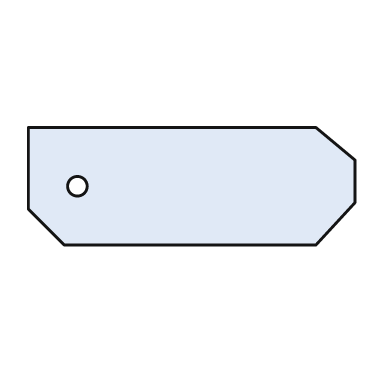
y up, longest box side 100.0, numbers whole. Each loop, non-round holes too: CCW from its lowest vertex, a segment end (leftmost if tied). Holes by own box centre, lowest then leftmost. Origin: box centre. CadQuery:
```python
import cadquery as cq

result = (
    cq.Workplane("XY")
    .moveTo(-39.0, -18.0)
    .lineTo(38.0, -18.0)
    .lineTo(50.0, -5.0)
    .lineTo(50.0, 8.0)
    .lineTo(38.0, 18.0)
    .lineTo(-50.0, 18.0)
    .lineTo(-50.0, -7.0)
    .close()
    .moveTo(-35.0, 0.0)
    .circle(3.0)
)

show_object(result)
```